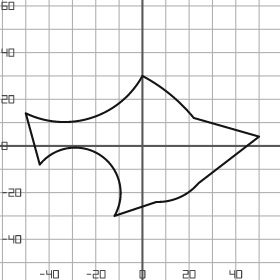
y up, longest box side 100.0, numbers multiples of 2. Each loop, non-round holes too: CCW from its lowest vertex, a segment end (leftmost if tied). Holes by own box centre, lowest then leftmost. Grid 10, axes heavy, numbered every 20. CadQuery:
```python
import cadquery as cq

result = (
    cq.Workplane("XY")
    .moveTo(-12.0, -30.0)
    .lineTo(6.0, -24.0)
    .threePointArc((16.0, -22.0), (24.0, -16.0))
    .lineTo(50.0, 4.0)
    .lineTo(22.0, 12.0)
    .threePointArc((12.0, 22.0), (0.0, 30.0))
    .threePointArc((-22.0, 12.0), (-50.0, 14.0))
    .lineTo(-44.0, -8.0)
    .threePointArc((-18.0, -4.0), (-12.0, -30.0))
    .close()
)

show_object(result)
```